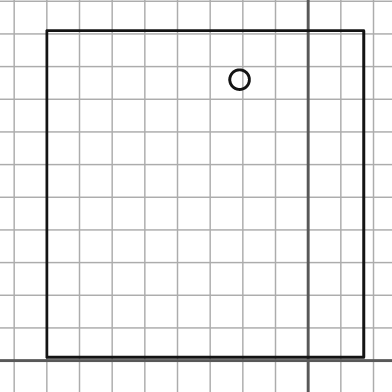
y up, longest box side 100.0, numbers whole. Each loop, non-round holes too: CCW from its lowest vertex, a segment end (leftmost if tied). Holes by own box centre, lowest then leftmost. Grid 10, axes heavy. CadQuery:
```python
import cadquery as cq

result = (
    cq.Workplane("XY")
    .moveTo(-80.0, 1.0)
    .lineTo(17.0, 1.0)
    .lineTo(17.0, 101.0)
    .lineTo(-80.0, 101.0)
    .close()
    .moveTo(-21.0, 86.0)
    .circle(3.0)
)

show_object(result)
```